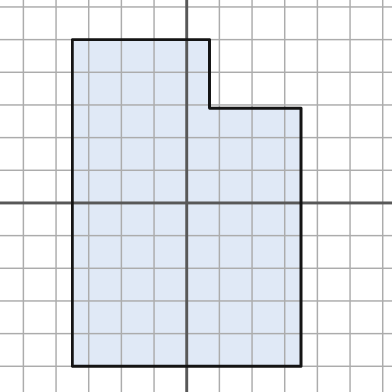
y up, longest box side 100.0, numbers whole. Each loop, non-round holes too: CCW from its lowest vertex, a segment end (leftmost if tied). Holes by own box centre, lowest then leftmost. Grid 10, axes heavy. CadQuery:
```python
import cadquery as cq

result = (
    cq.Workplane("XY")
    .moveTo(-35.0, -50.0)
    .lineTo(35.0, -50.0)
    .lineTo(35.0, 29.0)
    .lineTo(7.0, 29.0)
    .lineTo(7.0, 50.0)
    .lineTo(-35.0, 50.0)
    .close()
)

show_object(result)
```